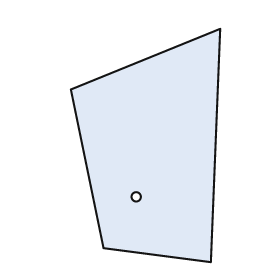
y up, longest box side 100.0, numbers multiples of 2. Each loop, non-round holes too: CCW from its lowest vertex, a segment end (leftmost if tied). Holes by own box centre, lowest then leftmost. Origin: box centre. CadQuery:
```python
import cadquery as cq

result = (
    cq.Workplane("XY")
    .moveTo(28.0, -50.0)
    .lineTo(32.0, 50.0)
    .lineTo(-32.0, 24.0)
    .lineTo(-18.0, -44.0)
    .close()
    .moveTo(-4.0, -22.0)
    .circle(2.0)
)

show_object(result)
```